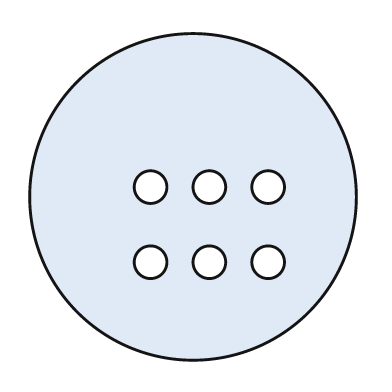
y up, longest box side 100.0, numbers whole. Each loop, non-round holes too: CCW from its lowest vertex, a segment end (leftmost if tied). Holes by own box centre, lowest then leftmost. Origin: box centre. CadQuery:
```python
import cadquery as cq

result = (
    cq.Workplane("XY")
    .moveTo(0.0, 0.0)
    .circle(50.0)
    .moveTo(-13.0, -20.0)
    .circle(5.0)
    .moveTo(5.0, -20.0)
    .circle(5.0)
    .moveTo(23.0, -20.0)
    .circle(5.0)
    .moveTo(-13.0, 3.0)
    .circle(5.0)
    .moveTo(5.0, 3.0)
    .circle(5.0)
    .moveTo(23.0, 3.0)
    .circle(5.0)
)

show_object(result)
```